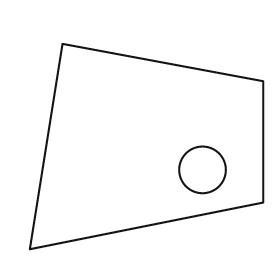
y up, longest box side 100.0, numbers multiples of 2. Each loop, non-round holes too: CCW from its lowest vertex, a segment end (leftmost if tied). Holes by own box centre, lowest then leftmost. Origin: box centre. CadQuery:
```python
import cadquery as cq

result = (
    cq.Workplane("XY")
    .moveTo(-50.0, -44.0)
    .lineTo(50.0, -24.0)
    .lineTo(50.0, 28.0)
    .lineTo(-36.0, 44.0)
    .close()
    .moveTo(24.0, -10.0)
    .circle(10.0)
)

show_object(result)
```